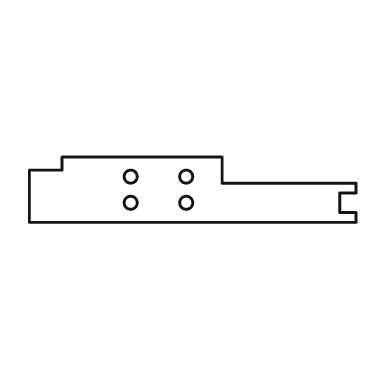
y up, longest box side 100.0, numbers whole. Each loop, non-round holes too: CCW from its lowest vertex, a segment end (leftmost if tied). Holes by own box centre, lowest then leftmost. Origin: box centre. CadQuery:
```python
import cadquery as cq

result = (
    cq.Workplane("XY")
    .moveTo(-50.0, -10.0)
    .lineTo(50.0, -10.0)
    .lineTo(50.0, -7.0)
    .lineTo(45.0, -7.0)
    .lineTo(45.0, -1.0)
    .lineTo(50.0, -1.0)
    .lineTo(50.0, 2.0)
    .lineTo(9.0, 2.0)
    .lineTo(9.0, 10.0)
    .lineTo(-40.0, 10.0)
    .lineTo(-40.0, 6.0)
    .lineTo(-50.0, 6.0)
    .close()
    .moveTo(-19.0, -4.0)
    .circle(2.0)
    .moveTo(-2.0, -4.0)
    .circle(2.0)
    .moveTo(-19.0, 4.0)
    .circle(2.0)
    .moveTo(-2.0, 4.0)
    .circle(2.0)
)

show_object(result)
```